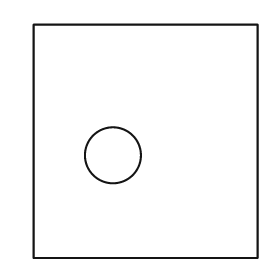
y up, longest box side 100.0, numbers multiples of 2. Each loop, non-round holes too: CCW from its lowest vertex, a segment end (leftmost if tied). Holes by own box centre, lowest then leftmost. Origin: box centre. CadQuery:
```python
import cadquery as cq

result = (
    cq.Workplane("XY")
    .moveTo(-48.0, -50.0)
    .lineTo(48.0, -50.0)
    .lineTo(48.0, 50.0)
    .lineTo(-48.0, 50.0)
    .close()
    .moveTo(-14.0, -6.0)
    .circle(12.0)
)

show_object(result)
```